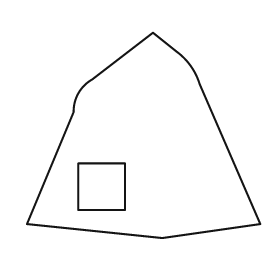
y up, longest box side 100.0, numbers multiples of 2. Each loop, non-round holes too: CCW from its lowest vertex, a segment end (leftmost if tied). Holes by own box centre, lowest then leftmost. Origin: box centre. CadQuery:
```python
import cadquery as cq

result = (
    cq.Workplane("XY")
    .moveTo(8.0, -44.0)
    .lineTo(50.0, -38.0)
    .lineTo(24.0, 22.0)
    .threePointArc((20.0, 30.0), (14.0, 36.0))
    .lineTo(4.0, 44.0)
    .lineTo(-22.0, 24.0)
    .threePointArc((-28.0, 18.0), (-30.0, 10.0))
    .lineTo(-50.0, -38.0)
    .close()
    .moveTo(-28.0, -32.0)
    .lineTo(-8.0, -32.0)
    .lineTo(-8.0, -12.0)
    .lineTo(-28.0, -12.0)
    .close()
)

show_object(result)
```